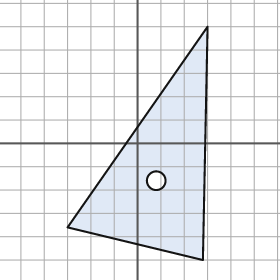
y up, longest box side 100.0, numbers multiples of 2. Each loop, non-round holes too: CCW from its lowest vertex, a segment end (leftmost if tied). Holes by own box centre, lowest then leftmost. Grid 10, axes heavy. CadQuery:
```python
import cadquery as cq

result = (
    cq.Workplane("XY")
    .moveTo(28.0, -50.0)
    .lineTo(30.0, 50.0)
    .lineTo(-30.0, -36.0)
    .close()
    .moveTo(8.0, -16.0)
    .circle(4.0)
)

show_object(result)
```